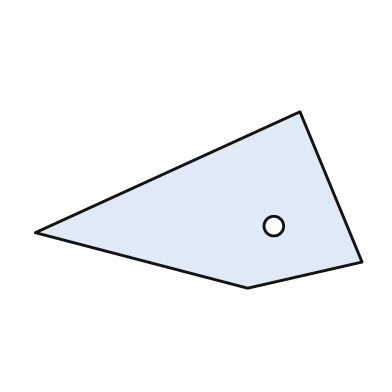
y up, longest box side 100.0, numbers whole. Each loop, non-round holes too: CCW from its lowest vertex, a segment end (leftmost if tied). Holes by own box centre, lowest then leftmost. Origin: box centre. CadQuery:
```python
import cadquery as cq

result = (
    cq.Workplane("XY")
    .moveTo(15.0, -27.0)
    .lineTo(50.0, -19.0)
    .lineTo(31.0, 27.0)
    .lineTo(-50.0, -10.0)
    .close()
    .moveTo(23.0, -8.0)
    .circle(3.0)
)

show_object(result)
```